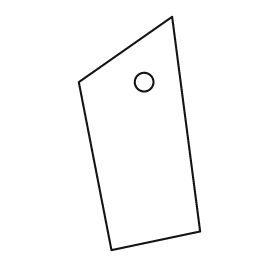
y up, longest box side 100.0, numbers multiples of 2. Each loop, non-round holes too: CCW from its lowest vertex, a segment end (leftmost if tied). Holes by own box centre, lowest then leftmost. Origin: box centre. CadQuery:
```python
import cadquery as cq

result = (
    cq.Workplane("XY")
    .moveTo(-12.0, -50.0)
    .lineTo(26.0, -42.0)
    .lineTo(14.0, 50.0)
    .lineTo(-26.0, 22.0)
    .close()
    .moveTo(2.0, 22.0)
    .circle(4.0)
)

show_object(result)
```